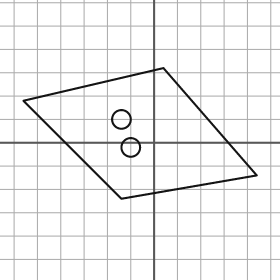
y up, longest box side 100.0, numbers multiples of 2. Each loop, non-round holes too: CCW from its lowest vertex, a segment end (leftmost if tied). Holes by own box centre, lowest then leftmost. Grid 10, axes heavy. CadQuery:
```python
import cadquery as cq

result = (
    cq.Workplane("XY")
    .moveTo(-14.0, -24.0)
    .lineTo(44.0, -14.0)
    .lineTo(4.0, 32.0)
    .lineTo(-56.0, 18.0)
    .close()
    .moveTo(-10.0, -2.0)
    .circle(4.0)
    .moveTo(-14.0, 10.0)
    .circle(4.0)
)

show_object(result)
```